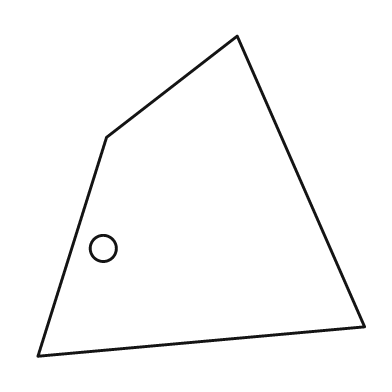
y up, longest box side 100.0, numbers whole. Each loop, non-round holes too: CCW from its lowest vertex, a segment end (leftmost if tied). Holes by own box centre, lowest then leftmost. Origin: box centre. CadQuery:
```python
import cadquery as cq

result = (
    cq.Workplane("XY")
    .moveTo(-50.0, -49.0)
    .lineTo(50.0, -40.0)
    .lineTo(11.0, 49.0)
    .lineTo(-29.0, 18.0)
    .close()
    .moveTo(-30.0, -16.0)
    .circle(4.0)
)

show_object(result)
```